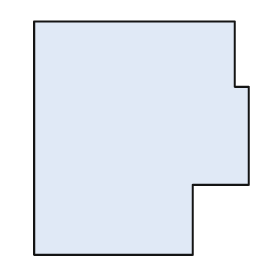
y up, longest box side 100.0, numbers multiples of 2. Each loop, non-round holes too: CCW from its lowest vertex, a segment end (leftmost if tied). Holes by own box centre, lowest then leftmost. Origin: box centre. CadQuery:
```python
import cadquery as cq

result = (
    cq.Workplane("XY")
    .moveTo(-46.0, -50.0)
    .lineTo(22.0, -50.0)
    .lineTo(22.0, -20.0)
    .lineTo(46.0, -20.0)
    .lineTo(46.0, 22.0)
    .lineTo(40.0, 22.0)
    .lineTo(40.0, 50.0)
    .lineTo(-46.0, 50.0)
    .close()
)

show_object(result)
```